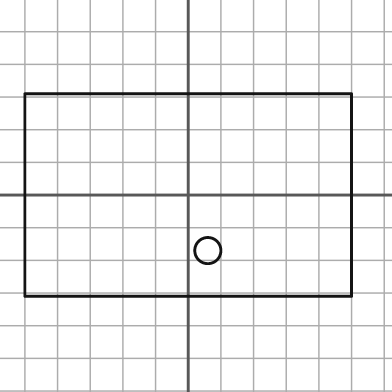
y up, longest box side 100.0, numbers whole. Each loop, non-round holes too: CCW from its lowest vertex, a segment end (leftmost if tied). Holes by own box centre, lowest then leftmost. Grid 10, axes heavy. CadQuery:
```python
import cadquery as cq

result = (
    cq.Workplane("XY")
    .moveTo(-50.0, -31.0)
    .lineTo(50.0, -31.0)
    .lineTo(50.0, 31.0)
    .lineTo(-50.0, 31.0)
    .close()
    .moveTo(6.0, -17.0)
    .circle(4.0)
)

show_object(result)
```